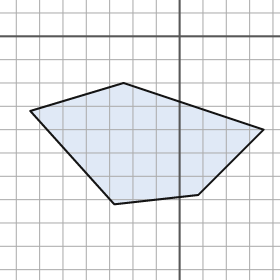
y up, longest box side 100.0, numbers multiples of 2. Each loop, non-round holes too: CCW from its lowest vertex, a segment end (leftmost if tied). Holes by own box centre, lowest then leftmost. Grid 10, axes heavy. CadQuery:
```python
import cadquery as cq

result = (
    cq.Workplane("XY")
    .moveTo(-28.0, -72.0)
    .lineTo(8.0, -68.0)
    .lineTo(36.0, -40.0)
    .lineTo(-24.0, -20.0)
    .lineTo(-64.0, -32.0)
    .close()
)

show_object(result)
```